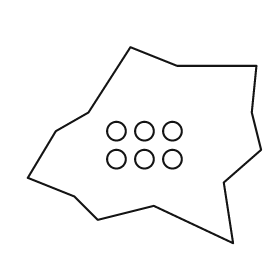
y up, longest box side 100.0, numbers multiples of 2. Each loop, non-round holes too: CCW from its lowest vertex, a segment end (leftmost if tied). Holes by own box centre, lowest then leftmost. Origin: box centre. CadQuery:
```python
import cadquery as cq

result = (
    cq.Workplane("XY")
    .moveTo(38.0, -42.0)
    .lineTo(34.0, -16.0)
    .lineTo(50.0, -2.0)
    .lineTo(46.0, 14.0)
    .lineTo(48.0, 34.0)
    .lineTo(14.0, 34.0)
    .lineTo(-6.0, 42.0)
    .lineTo(-24.0, 14.0)
    .lineTo(-38.0, 6.0)
    .lineTo(-50.0, -14.0)
    .lineTo(-30.0, -22.0)
    .lineTo(-20.0, -32.0)
    .lineTo(4.0, -26.0)
    .close()
    .moveTo(-12.0, -6.0)
    .circle(4.0)
    .moveTo(0.0, -6.0)
    .circle(4.0)
    .moveTo(12.0, -6.0)
    .circle(4.0)
    .moveTo(-12.0, 6.0)
    .circle(4.0)
    .moveTo(0.0, 6.0)
    .circle(4.0)
    .moveTo(12.0, 6.0)
    .circle(4.0)
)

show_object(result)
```